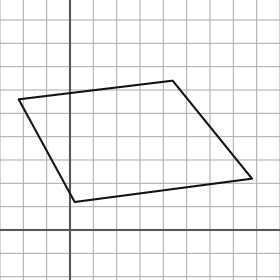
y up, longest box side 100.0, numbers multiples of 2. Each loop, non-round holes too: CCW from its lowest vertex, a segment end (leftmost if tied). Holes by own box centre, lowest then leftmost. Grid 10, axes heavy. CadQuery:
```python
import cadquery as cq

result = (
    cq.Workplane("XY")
    .moveTo(2.0, 12.0)
    .lineTo(78.0, 22.0)
    .lineTo(44.0, 64.0)
    .lineTo(-22.0, 56.0)
    .close()
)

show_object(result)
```